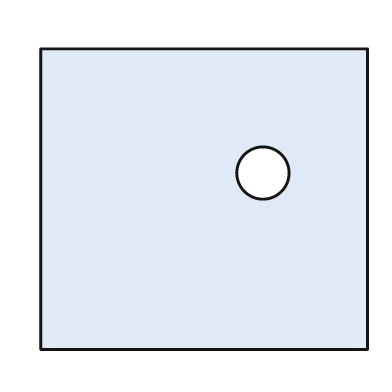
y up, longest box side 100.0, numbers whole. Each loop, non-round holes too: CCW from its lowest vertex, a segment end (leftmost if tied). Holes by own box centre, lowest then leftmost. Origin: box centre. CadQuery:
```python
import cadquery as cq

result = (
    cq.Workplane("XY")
    .moveTo(-50.0, -46.0)
    .lineTo(50.0, -46.0)
    .lineTo(50.0, 46.0)
    .lineTo(-50.0, 46.0)
    .close()
    .moveTo(18.0, 8.0)
    .circle(8.0)
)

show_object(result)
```